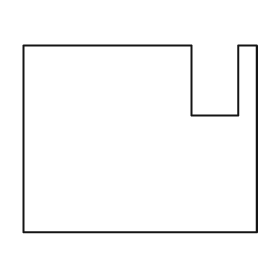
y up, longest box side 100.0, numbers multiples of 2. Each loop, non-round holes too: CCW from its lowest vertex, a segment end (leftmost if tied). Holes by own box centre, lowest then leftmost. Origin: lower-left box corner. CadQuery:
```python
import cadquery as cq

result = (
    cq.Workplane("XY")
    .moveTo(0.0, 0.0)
    .lineTo(100.0, 0.0)
    .lineTo(100.0, 80.0)
    .lineTo(92.0, 80.0)
    .lineTo(92.0, 50.0)
    .lineTo(72.0, 50.0)
    .lineTo(72.0, 80.0)
    .lineTo(0.0, 80.0)
    .close()
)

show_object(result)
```